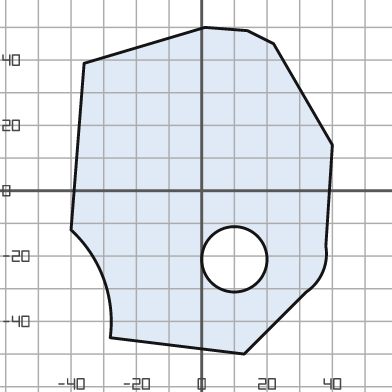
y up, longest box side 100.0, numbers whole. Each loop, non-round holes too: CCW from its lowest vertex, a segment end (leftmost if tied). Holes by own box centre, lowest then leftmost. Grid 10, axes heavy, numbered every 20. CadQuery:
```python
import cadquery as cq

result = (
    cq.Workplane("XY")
    .moveTo(13.0, -50.0)
    .lineTo(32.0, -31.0)
    .threePointArc((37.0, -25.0), (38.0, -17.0))
    .lineTo(40.0, 14.0)
    .lineTo(22.0, 45.0)
    .lineTo(14.0, 49.0)
    .lineTo(1.0, 50.0)
    .lineTo(-36.0, 39.0)
    .lineTo(-40.0, -12.0)
    .threePointArc((-30.0, -27.0), (-28.0, -45.0))
    .close()
    .moveTo(10.0, -21.0)
    .circle(10.0)
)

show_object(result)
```